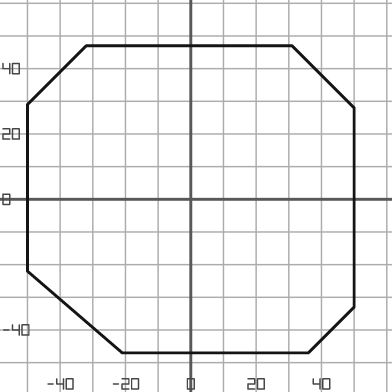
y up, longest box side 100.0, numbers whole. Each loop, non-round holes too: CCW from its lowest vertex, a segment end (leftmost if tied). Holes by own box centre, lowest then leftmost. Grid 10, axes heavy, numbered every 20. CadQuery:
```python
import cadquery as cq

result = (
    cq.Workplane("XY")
    .moveTo(-21.0, -47.0)
    .lineTo(36.0, -47.0)
    .lineTo(50.0, -33.0)
    .lineTo(50.0, 28.0)
    .lineTo(31.0, 47.0)
    .lineTo(-32.0, 47.0)
    .lineTo(-50.0, 29.0)
    .lineTo(-50.0, -22.0)
    .close()
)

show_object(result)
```